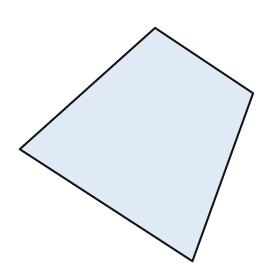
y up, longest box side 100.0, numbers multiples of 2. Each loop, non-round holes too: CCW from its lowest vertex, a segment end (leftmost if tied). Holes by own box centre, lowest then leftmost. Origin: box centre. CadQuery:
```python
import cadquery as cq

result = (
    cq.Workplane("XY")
    .moveTo(24.0, -50.0)
    .lineTo(50.0, 22.0)
    .lineTo(8.0, 50.0)
    .lineTo(-50.0, -2.0)
    .close()
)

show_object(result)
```